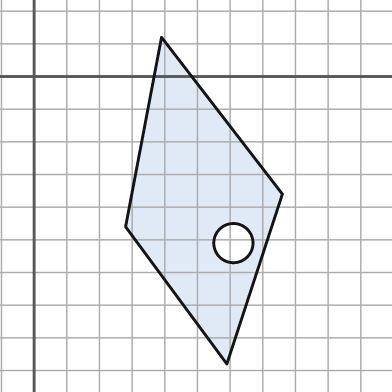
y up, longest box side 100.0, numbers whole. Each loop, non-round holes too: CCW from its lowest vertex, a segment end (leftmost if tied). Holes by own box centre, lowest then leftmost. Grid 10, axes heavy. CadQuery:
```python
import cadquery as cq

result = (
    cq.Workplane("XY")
    .moveTo(59.0, -88.0)
    .lineTo(76.0, -36.0)
    .lineTo(39.0, 12.0)
    .lineTo(28.0, -46.0)
    .close()
    .moveTo(61.0, -51.0)
    .circle(6.0)
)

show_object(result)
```